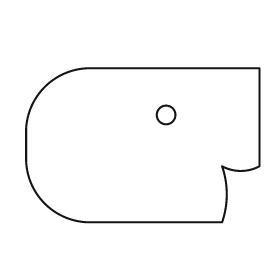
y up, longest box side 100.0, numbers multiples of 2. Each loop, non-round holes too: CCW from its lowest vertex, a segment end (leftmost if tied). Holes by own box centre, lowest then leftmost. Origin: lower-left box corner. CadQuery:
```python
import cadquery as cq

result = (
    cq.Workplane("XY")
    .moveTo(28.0, 0.0)
    .lineTo(84.0, 0.0)
    .threePointArc((86.0, 12.0), (84.0, 24.0))
    .threePointArc((92.0, 22.0), (100.0, 24.0))
    .lineTo(100.0, 66.0)
    .lineTo(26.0, 66.0)
    .threePointArc((8.0, 58.0), (0.0, 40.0))
    .lineTo(0.0, 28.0)
    .threePointArc((8.0, 8.0), (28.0, 0.0))
    .close()
    .moveTo(60.0, 46.0)
    .circle(4.0)
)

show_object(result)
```